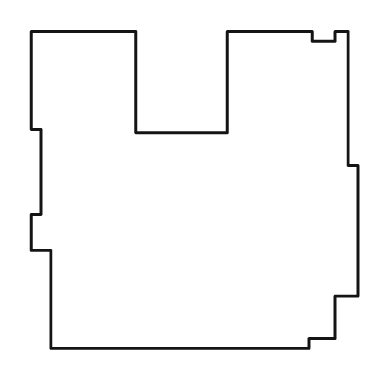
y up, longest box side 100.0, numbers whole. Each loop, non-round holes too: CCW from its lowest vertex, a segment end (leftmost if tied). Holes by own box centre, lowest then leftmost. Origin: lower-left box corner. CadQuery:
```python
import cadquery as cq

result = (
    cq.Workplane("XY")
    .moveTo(6.0, 0.0)
    .lineTo(85.0, 0.0)
    .lineTo(85.0, 3.0)
    .lineTo(93.0, 3.0)
    .lineTo(93.0, 16.0)
    .lineTo(100.0, 16.0)
    .lineTo(100.0, 56.0)
    .lineTo(97.0, 56.0)
    .lineTo(97.0, 97.0)
    .lineTo(93.0, 97.0)
    .lineTo(93.0, 94.0)
    .lineTo(86.0, 94.0)
    .lineTo(86.0, 97.0)
    .lineTo(60.0, 97.0)
    .lineTo(60.0, 66.0)
    .lineTo(32.0, 66.0)
    .lineTo(32.0, 97.0)
    .lineTo(0.0, 97.0)
    .lineTo(0.0, 67.0)
    .lineTo(3.0, 67.0)
    .lineTo(3.0, 41.0)
    .lineTo(0.0, 41.0)
    .lineTo(0.0, 30.0)
    .lineTo(6.0, 30.0)
    .close()
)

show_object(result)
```